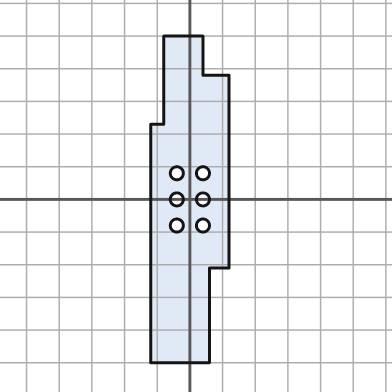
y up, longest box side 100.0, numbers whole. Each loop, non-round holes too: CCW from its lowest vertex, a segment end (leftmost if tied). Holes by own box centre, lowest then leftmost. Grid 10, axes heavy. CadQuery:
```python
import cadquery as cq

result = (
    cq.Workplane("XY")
    .moveTo(-12.0, -50.0)
    .lineTo(6.0, -50.0)
    .lineTo(6.0, -21.0)
    .lineTo(12.0, -21.0)
    .lineTo(12.0, 38.0)
    .lineTo(4.0, 38.0)
    .lineTo(4.0, 50.0)
    .lineTo(-8.0, 50.0)
    .lineTo(-8.0, 23.0)
    .lineTo(-12.0, 23.0)
    .close()
    .moveTo(-4.0, -8.0)
    .circle(2.0)
    .moveTo(4.0, -8.0)
    .circle(2.0)
    .moveTo(-4.0, 0.0)
    .circle(2.0)
    .moveTo(4.0, 0.0)
    .circle(2.0)
    .moveTo(-4.0, 8.0)
    .circle(2.0)
    .moveTo(4.0, 8.0)
    .circle(2.0)
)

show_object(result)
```